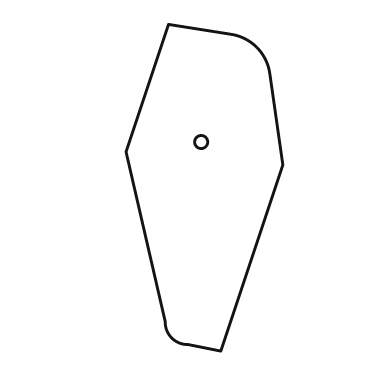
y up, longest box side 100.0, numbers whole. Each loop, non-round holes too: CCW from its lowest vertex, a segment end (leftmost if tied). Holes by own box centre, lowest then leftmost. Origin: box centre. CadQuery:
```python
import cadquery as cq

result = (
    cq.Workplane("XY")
    .moveTo(5.0, -50.0)
    .lineTo(24.0, 7.0)
    .lineTo(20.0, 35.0)
    .threePointArc((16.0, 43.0), (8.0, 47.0))
    .lineTo(-11.0, 50.0)
    .lineTo(-24.0, 11.0)
    .lineTo(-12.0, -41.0)
    .threePointArc((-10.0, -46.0), (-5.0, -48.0))
    .close()
    .moveTo(-1.0, 14.0)
    .circle(2.0)
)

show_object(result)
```